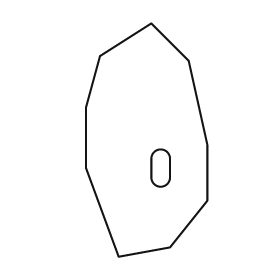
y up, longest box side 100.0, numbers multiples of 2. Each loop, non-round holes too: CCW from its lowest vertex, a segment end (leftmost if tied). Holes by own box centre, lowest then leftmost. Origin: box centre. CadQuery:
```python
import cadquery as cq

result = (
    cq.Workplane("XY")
    .moveTo(-12.0, -50.0)
    .lineTo(10.0, -46.0)
    .lineTo(26.0, -26.0)
    .lineTo(26.0, -2.0)
    .lineTo(18.0, 34.0)
    .lineTo(2.0, 50.0)
    .lineTo(-20.0, 36.0)
    .lineTo(-26.0, 14.0)
    .lineTo(-26.0, -12.0)
    .close()
    .moveTo(2.0, -16.0)
    .threePointArc((6.0, -20.0), (10.0, -16.0))
    .lineTo(10.0, -8.0)
    .threePointArc((6.0, -4.0), (2.0, -8.0))
    .close()
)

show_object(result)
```